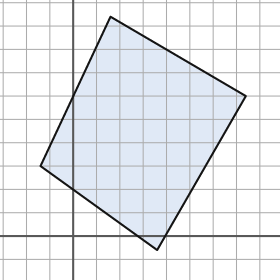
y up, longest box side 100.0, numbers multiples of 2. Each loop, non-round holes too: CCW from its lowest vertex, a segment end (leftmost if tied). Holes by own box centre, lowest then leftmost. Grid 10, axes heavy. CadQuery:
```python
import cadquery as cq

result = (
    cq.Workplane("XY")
    .moveTo(36.0, -6.0)
    .lineTo(74.0, 60.0)
    .lineTo(16.0, 94.0)
    .lineTo(-14.0, 30.0)
    .close()
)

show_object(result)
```